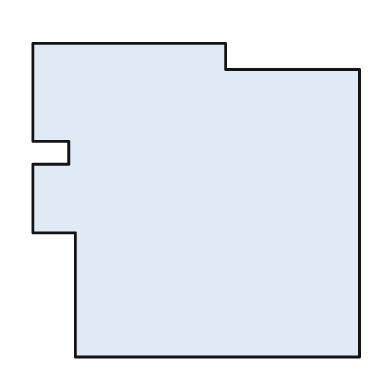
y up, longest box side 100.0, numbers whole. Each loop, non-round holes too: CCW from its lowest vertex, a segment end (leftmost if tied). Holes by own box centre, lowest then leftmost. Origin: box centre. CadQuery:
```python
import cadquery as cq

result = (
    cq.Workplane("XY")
    .moveTo(-37.0, -48.0)
    .lineTo(50.0, -48.0)
    .lineTo(50.0, 40.0)
    .lineTo(9.0, 40.0)
    .lineTo(9.0, 48.0)
    .lineTo(-50.0, 48.0)
    .lineTo(-50.0, 18.0)
    .lineTo(-39.0, 18.0)
    .lineTo(-39.0, 11.0)
    .lineTo(-50.0, 11.0)
    .lineTo(-50.0, -10.0)
    .lineTo(-37.0, -10.0)
    .close()
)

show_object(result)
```